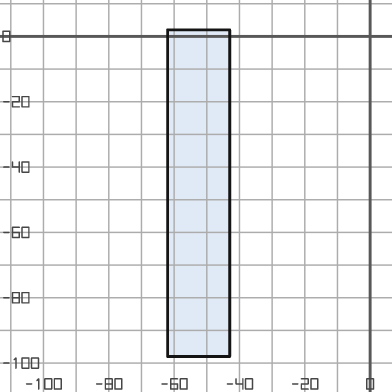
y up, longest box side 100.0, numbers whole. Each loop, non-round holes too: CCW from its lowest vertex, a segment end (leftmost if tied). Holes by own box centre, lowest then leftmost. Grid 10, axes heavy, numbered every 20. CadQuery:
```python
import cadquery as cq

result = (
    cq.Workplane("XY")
    .moveTo(-62.0, -98.0)
    .lineTo(-43.0, -98.0)
    .lineTo(-43.0, 2.0)
    .lineTo(-62.0, 2.0)
    .close()
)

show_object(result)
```